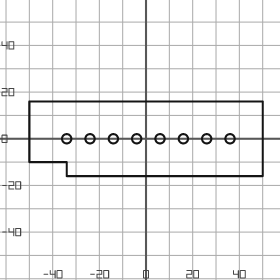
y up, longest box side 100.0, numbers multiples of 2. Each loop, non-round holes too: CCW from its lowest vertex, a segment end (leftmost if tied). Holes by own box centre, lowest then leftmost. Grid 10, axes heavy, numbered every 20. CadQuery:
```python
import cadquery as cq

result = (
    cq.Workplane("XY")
    .moveTo(-34.0, -16.0)
    .lineTo(50.0, -16.0)
    .lineTo(50.0, 16.0)
    .lineTo(-50.0, 16.0)
    .lineTo(-50.0, -10.0)
    .lineTo(-34.0, -10.0)
    .close()
    .moveTo(-34.0, 0.0)
    .circle(2.0)
    .moveTo(-24.0, 0.0)
    .circle(2.0)
    .moveTo(-14.0, 0.0)
    .circle(2.0)
    .moveTo(-4.0, 0.0)
    .circle(2.0)
    .moveTo(6.0, 0.0)
    .circle(2.0)
    .moveTo(16.0, 0.0)
    .circle(2.0)
    .moveTo(26.0, 0.0)
    .circle(2.0)
    .moveTo(36.0, 0.0)
    .circle(2.0)
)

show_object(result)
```